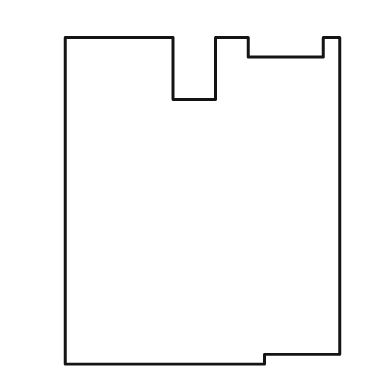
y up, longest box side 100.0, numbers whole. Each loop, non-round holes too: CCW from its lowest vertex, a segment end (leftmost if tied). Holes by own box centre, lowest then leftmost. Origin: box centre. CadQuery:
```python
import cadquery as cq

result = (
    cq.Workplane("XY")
    .moveTo(-42.0, -50.0)
    .lineTo(19.0, -50.0)
    .lineTo(19.0, -47.0)
    .lineTo(42.0, -47.0)
    .lineTo(42.0, 50.0)
    .lineTo(37.0, 50.0)
    .lineTo(37.0, 44.0)
    .lineTo(14.0, 44.0)
    .lineTo(14.0, 50.0)
    .lineTo(4.0, 50.0)
    .lineTo(4.0, 31.0)
    .lineTo(-9.0, 31.0)
    .lineTo(-9.0, 50.0)
    .lineTo(-42.0, 50.0)
    .close()
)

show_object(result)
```